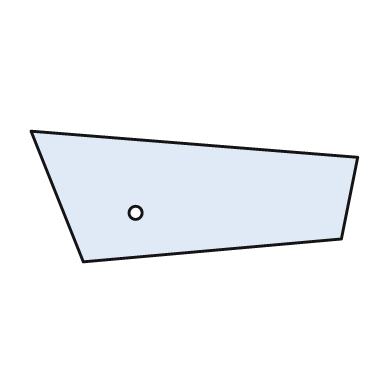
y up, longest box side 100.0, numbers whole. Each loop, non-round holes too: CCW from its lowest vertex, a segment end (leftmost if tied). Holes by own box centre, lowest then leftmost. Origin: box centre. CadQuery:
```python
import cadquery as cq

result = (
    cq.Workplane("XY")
    .moveTo(-34.0, -20.0)
    .lineTo(45.0, -13.0)
    .lineTo(50.0, 12.0)
    .lineTo(-50.0, 20.0)
    .close()
    .moveTo(-18.0, -5.0)
    .circle(2.0)
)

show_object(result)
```